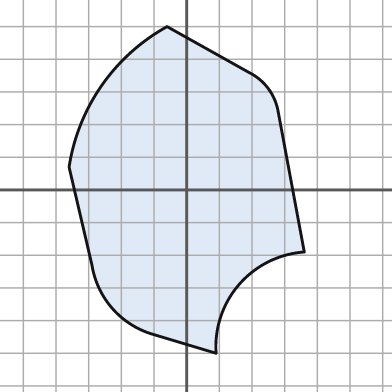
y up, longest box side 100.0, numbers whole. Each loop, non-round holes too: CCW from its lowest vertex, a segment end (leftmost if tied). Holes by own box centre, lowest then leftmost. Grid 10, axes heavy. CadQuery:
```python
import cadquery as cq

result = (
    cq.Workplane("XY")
    .moveTo(9.0, -50.0)
    .threePointArc((16.0, -29.0), (36.0, -19.0))
    .lineTo(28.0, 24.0)
    .threePointArc((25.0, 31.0), (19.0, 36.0))
    .lineTo(-6.0, 50.0)
    .threePointArc((-26.0, 32.0), (-36.0, 7.0))
    .lineTo(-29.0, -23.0)
    .threePointArc((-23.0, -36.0), (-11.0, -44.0))
    .close()
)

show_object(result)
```